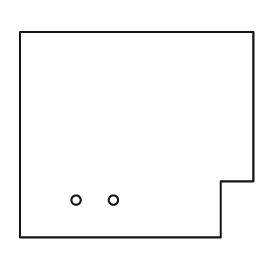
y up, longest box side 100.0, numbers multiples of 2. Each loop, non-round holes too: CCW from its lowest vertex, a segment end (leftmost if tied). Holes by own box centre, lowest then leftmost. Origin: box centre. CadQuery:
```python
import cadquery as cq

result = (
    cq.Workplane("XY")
    .moveTo(-50.0, -44.0)
    .lineTo(36.0, -44.0)
    .lineTo(36.0, -20.0)
    .lineTo(50.0, -20.0)
    .lineTo(50.0, 44.0)
    .lineTo(-50.0, 44.0)
    .close()
    .moveTo(-26.0, -28.0)
    .circle(2.0)
    .moveTo(-10.0, -28.0)
    .circle(2.0)
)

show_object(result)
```